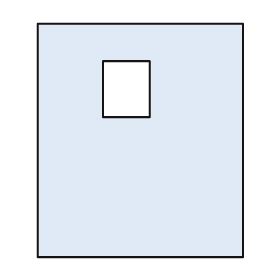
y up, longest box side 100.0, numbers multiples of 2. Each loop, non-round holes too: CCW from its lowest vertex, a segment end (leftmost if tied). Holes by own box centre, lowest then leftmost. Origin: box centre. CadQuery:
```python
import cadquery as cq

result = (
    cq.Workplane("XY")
    .moveTo(-44.0, -50.0)
    .lineTo(44.0, -50.0)
    .lineTo(44.0, 50.0)
    .lineTo(-44.0, 50.0)
    .close()
    .moveTo(-16.0, 10.0)
    .lineTo(4.0, 10.0)
    .lineTo(4.0, 34.0)
    .lineTo(-16.0, 34.0)
    .close()
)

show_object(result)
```